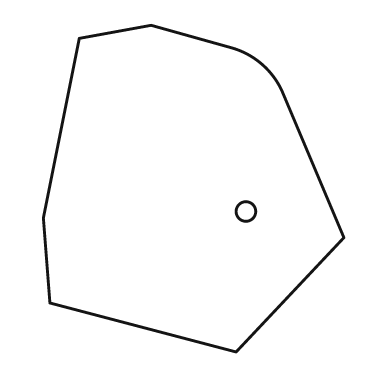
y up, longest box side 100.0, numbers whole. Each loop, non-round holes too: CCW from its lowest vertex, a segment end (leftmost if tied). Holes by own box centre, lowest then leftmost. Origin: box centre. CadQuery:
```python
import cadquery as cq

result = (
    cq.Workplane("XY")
    .moveTo(13.0, -50.0)
    .lineTo(46.0, -15.0)
    .lineTo(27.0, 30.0)
    .threePointArc((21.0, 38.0), (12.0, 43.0))
    .lineTo(-13.0, 50.0)
    .lineTo(-35.0, 46.0)
    .lineTo(-46.0, -9.0)
    .lineTo(-44.0, -35.0)
    .close()
    .moveTo(16.0, -7.0)
    .circle(3.0)
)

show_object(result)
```